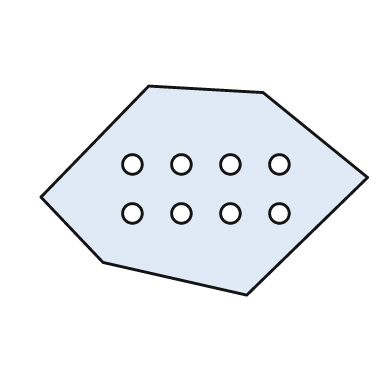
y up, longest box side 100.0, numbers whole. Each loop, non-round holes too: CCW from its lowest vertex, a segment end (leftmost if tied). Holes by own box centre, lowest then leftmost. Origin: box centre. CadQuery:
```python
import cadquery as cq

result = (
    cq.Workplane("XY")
    .moveTo(13.0, -32.0)
    .lineTo(50.0, 4.0)
    .lineTo(18.0, 30.0)
    .lineTo(-17.0, 32.0)
    .lineTo(-50.0, -2.0)
    .lineTo(-31.0, -22.0)
    .close()
    .moveTo(-22.0, -7.0)
    .circle(3.0)
    .moveTo(-7.0, -7.0)
    .circle(3.0)
    .moveTo(8.0, -7.0)
    .circle(3.0)
    .moveTo(23.0, -7.0)
    .circle(3.0)
    .moveTo(-22.0, 8.0)
    .circle(3.0)
    .moveTo(-7.0, 8.0)
    .circle(3.0)
    .moveTo(8.0, 8.0)
    .circle(3.0)
    .moveTo(23.0, 8.0)
    .circle(3.0)
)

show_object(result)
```